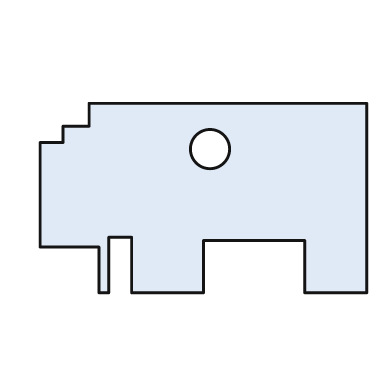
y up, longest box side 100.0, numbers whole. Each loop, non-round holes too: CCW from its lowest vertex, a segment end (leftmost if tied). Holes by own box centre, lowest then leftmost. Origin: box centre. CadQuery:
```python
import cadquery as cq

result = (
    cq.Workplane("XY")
    .moveTo(-32.0, -29.0)
    .lineTo(-29.0, -29.0)
    .lineTo(-29.0, -12.0)
    .lineTo(-22.0, -12.0)
    .lineTo(-22.0, -29.0)
    .lineTo(0.0, -29.0)
    .lineTo(0.0, -13.0)
    .lineTo(31.0, -13.0)
    .lineTo(31.0, -29.0)
    .lineTo(50.0, -29.0)
    .lineTo(50.0, 29.0)
    .lineTo(-35.0, 29.0)
    .lineTo(-35.0, 22.0)
    .lineTo(-43.0, 22.0)
    .lineTo(-43.0, 17.0)
    .lineTo(-50.0, 17.0)
    .lineTo(-50.0, -15.0)
    .lineTo(-32.0, -15.0)
    .close()
    .moveTo(2.0, 15.0)
    .circle(6.0)
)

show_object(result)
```